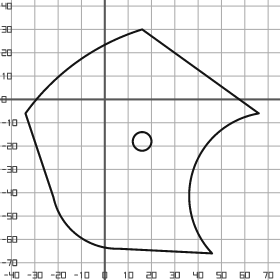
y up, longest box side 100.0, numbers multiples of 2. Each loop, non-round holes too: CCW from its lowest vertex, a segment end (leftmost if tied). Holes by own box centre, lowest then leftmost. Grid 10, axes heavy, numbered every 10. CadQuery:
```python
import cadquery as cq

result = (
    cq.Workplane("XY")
    .moveTo(46.0, -66.0)
    .threePointArc((38.0, -30.0), (66.0, -6.0))
    .lineTo(16.0, 30.0)
    .threePointArc((-12.0, 16.0), (-34.0, -6.0))
    .lineTo(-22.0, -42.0)
    .threePointArc((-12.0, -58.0), (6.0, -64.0))
    .close()
    .moveTo(16.0, -18.0)
    .circle(4.0)
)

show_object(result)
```